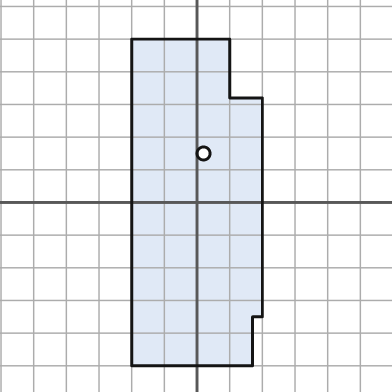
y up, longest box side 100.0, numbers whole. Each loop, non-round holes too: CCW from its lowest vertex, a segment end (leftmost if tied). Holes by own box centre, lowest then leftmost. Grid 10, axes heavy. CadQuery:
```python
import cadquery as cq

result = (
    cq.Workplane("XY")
    .moveTo(-20.0, -50.0)
    .lineTo(17.0, -50.0)
    .lineTo(17.0, -35.0)
    .lineTo(20.0, -35.0)
    .lineTo(20.0, 32.0)
    .lineTo(10.0, 32.0)
    .lineTo(10.0, 50.0)
    .lineTo(-20.0, 50.0)
    .close()
    .moveTo(2.0, 15.0)
    .circle(2.0)
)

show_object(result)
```